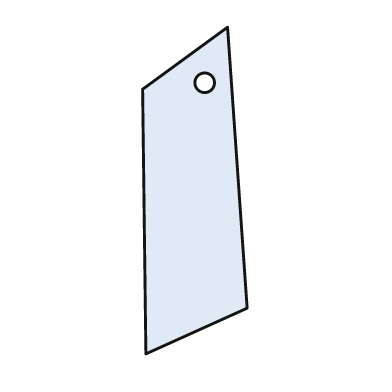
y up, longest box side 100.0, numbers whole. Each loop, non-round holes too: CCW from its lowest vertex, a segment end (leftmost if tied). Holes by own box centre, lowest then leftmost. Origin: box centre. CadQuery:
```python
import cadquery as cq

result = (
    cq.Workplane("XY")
    .moveTo(-15.0, -50.0)
    .lineTo(16.0, -36.0)
    .lineTo(10.0, 50.0)
    .lineTo(-16.0, 31.0)
    .close()
    .moveTo(3.0, 33.0)
    .circle(3.0)
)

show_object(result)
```